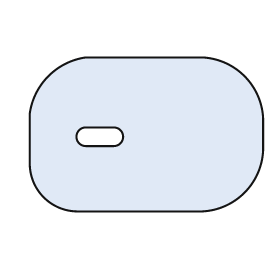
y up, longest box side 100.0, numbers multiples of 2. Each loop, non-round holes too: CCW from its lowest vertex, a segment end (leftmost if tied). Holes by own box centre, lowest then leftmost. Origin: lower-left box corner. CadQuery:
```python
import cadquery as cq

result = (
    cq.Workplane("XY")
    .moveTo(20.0, 0.0)
    .lineTo(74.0, 0.0)
    .threePointArc((92.0, 8.0), (100.0, 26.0))
    .lineTo(100.0, 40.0)
    .threePointArc((92.0, 58.0), (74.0, 66.0))
    .lineTo(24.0, 66.0)
    .threePointArc((8.0, 58.0), (0.0, 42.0))
    .lineTo(0.0, 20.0)
    .threePointArc((6.0, 6.0), (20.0, 0.0))
    .close()
    .moveTo(24.0, 28.0)
    .lineTo(36.0, 28.0)
    .threePointArc((40.0, 32.0), (36.0, 36.0))
    .lineTo(24.0, 36.0)
    .threePointArc((20.0, 32.0), (24.0, 28.0))
    .close()
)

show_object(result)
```